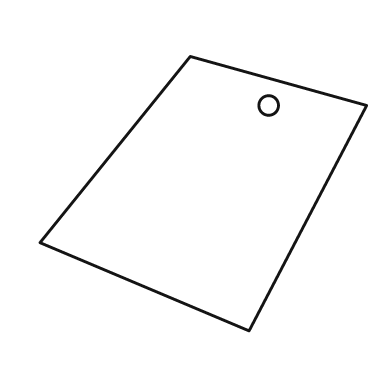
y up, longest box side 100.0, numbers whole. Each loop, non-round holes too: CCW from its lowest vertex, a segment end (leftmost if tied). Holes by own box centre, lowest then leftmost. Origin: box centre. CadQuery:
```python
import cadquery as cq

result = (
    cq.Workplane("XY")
    .moveTo(14.0, -42.0)
    .lineTo(50.0, 27.0)
    .lineTo(-4.0, 42.0)
    .lineTo(-50.0, -15.0)
    .close()
    .moveTo(20.0, 27.0)
    .circle(3.0)
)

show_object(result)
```